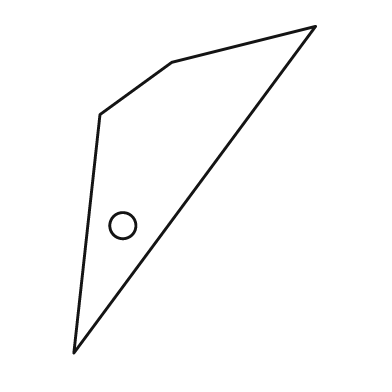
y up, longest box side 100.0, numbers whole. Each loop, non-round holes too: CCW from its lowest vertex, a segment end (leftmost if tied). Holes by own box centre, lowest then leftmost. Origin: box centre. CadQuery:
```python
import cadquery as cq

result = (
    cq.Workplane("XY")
    .moveTo(-37.0, -50.0)
    .lineTo(37.0, 50.0)
    .lineTo(-7.0, 39.0)
    .lineTo(-29.0, 23.0)
    .close()
    .moveTo(-22.0, -11.0)
    .circle(4.0)
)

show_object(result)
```